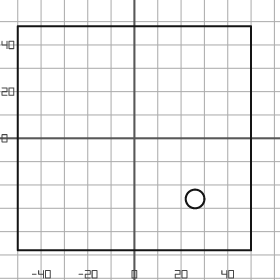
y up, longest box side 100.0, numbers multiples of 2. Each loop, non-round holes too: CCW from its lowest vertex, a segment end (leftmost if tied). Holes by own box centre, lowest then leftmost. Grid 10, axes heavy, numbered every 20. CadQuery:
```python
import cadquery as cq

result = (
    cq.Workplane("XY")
    .moveTo(-50.0, -48.0)
    .lineTo(50.0, -48.0)
    .lineTo(50.0, 48.0)
    .lineTo(-50.0, 48.0)
    .close()
    .moveTo(26.0, -26.0)
    .circle(4.0)
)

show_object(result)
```